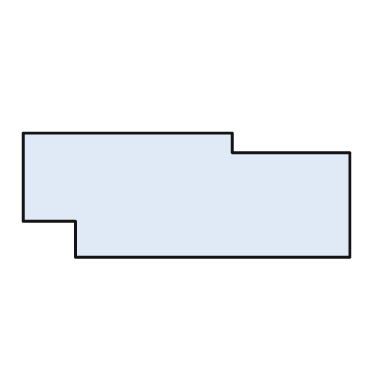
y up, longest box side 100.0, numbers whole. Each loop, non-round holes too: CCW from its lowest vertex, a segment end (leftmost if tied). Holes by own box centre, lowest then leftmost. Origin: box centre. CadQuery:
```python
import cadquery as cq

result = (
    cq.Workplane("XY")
    .moveTo(-34.0, -19.0)
    .lineTo(50.0, -19.0)
    .lineTo(50.0, 13.0)
    .lineTo(14.0, 13.0)
    .lineTo(14.0, 19.0)
    .lineTo(-50.0, 19.0)
    .lineTo(-50.0, -8.0)
    .lineTo(-34.0, -8.0)
    .close()
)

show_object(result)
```